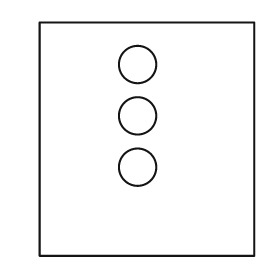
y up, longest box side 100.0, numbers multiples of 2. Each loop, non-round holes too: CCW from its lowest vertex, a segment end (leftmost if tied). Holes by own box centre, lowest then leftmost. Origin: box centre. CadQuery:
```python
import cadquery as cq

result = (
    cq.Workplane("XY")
    .moveTo(-46.0, -50.0)
    .lineTo(46.0, -50.0)
    .lineTo(46.0, 50.0)
    .lineTo(-46.0, 50.0)
    .close()
    .moveTo(-4.0, -12.0)
    .circle(8.0)
    .moveTo(-4.0, 10.0)
    .circle(8.0)
    .moveTo(-4.0, 32.0)
    .circle(8.0)
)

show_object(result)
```